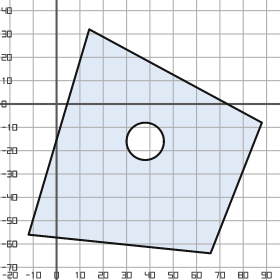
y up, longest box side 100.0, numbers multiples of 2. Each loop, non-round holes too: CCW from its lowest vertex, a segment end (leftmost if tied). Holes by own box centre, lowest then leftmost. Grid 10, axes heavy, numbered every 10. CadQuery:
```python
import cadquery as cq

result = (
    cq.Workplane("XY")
    .moveTo(66.0, -64.0)
    .lineTo(88.0, -8.0)
    .lineTo(14.0, 32.0)
    .lineTo(-12.0, -56.0)
    .close()
    .moveTo(38.0, -16.0)
    .circle(8.0)
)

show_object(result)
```